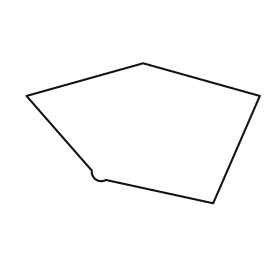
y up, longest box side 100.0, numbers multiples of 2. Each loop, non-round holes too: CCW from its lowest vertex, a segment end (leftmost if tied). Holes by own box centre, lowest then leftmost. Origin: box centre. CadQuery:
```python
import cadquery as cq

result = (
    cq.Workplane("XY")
    .moveTo(30.0, -30.0)
    .lineTo(50.0, 16.0)
    .lineTo(0.0, 30.0)
    .lineTo(-50.0, 16.0)
    .lineTo(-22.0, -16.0)
    .threePointArc((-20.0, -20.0), (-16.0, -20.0))
    .close()
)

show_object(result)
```